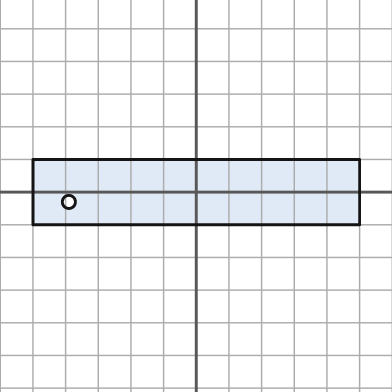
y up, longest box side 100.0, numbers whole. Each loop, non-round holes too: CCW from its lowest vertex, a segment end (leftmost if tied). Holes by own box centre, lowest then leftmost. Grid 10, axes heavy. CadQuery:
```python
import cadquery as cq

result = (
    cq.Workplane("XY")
    .moveTo(-50.0, -10.0)
    .lineTo(50.0, -10.0)
    .lineTo(50.0, 10.0)
    .lineTo(-50.0, 10.0)
    .close()
    .moveTo(-39.0, -3.0)
    .circle(2.0)
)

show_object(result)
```